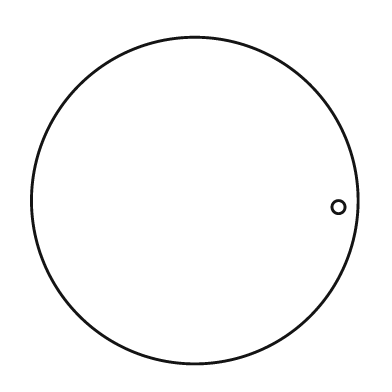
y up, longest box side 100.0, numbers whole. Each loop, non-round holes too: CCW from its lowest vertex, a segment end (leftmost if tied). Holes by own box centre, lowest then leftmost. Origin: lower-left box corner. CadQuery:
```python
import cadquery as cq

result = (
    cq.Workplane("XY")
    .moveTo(50.0, 50.0)
    .circle(50.0)
    .moveTo(94.0, 48.0)
    .circle(2.0)
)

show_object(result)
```